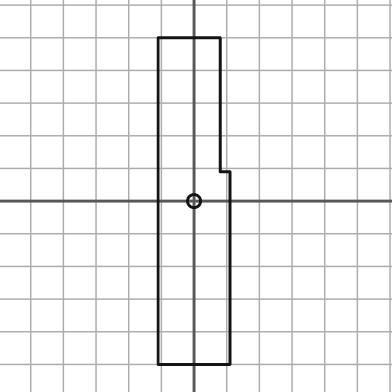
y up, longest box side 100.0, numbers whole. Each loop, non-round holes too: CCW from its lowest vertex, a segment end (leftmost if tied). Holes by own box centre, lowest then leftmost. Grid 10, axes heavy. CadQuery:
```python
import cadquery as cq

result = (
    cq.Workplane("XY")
    .moveTo(-11.0, -50.0)
    .lineTo(11.0, -50.0)
    .lineTo(11.0, 9.0)
    .lineTo(8.0, 9.0)
    .lineTo(8.0, 50.0)
    .lineTo(-11.0, 50.0)
    .close()
    .moveTo(0.0, 0.0)
    .circle(2.0)
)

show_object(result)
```